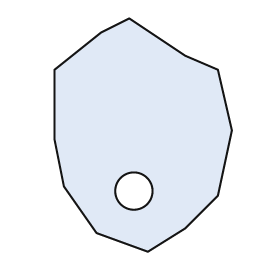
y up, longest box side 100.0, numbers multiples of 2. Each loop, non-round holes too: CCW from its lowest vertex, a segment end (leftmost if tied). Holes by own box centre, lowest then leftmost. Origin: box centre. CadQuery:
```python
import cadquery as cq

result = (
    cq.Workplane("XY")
    .moveTo(2.0, -50.0)
    .lineTo(18.0, -40.0)
    .lineTo(32.0, -26.0)
    .lineTo(38.0, 2.0)
    .lineTo(32.0, 28.0)
    .lineTo(18.0, 34.0)
    .lineTo(-6.0, 50.0)
    .lineTo(-18.0, 44.0)
    .lineTo(-38.0, 28.0)
    .lineTo(-38.0, -2.0)
    .lineTo(-34.0, -22.0)
    .lineTo(-20.0, -42.0)
    .close()
    .moveTo(-4.0, -24.0)
    .circle(8.0)
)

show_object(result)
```